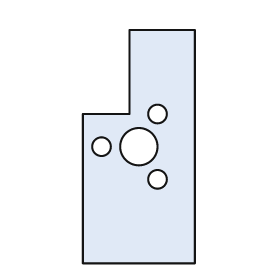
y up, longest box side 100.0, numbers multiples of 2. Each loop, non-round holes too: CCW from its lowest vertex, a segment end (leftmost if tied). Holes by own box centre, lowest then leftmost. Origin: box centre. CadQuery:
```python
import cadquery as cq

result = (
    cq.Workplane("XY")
    .moveTo(-24.0, -50.0)
    .lineTo(24.0, -50.0)
    .lineTo(24.0, 50.0)
    .lineTo(-4.0, 50.0)
    .lineTo(-4.0, 14.0)
    .lineTo(-24.0, 14.0)
    .close()
    .moveTo(8.0, -14.0)
    .circle(4.0)
    .moveTo(-16.0, 0.0)
    .circle(4.0)
    .moveTo(0.0, 0.0)
    .circle(8.0)
    .moveTo(8.0, 14.0)
    .circle(4.0)
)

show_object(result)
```